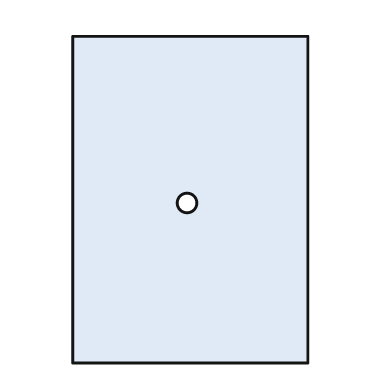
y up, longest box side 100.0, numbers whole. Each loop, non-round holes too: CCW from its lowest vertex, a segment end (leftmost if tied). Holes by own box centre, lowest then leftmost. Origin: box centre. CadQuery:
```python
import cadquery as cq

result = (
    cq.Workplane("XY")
    .moveTo(-36.0, -50.0)
    .lineTo(36.0, -50.0)
    .lineTo(36.0, 50.0)
    .lineTo(-36.0, 50.0)
    .close()
    .moveTo(-1.0, -1.0)
    .circle(3.0)
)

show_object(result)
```